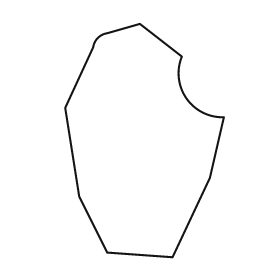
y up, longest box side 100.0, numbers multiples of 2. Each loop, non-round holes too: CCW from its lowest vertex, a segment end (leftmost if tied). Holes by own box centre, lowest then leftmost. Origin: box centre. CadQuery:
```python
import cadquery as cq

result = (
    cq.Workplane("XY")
    .moveTo(12.0, -50.0)
    .lineTo(28.0, -16.0)
    .lineTo(34.0, 10.0)
    .threePointArc((18.0, 18.0), (16.0, 36.0))
    .lineTo(-2.0, 50.0)
    .lineTo(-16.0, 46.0)
    .threePointArc((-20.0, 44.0), (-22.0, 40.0))
    .lineTo(-34.0, 14.0)
    .lineTo(-28.0, -24.0)
    .lineTo(-16.0, -48.0)
    .close()
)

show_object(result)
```